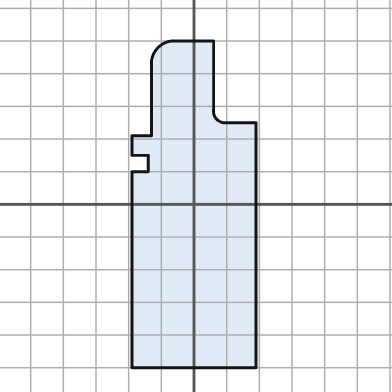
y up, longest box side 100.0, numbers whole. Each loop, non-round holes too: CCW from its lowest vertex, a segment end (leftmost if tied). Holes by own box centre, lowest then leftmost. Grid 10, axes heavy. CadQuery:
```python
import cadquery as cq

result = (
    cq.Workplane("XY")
    .moveTo(-19.0, -50.0)
    .lineTo(19.0, -50.0)
    .lineTo(19.0, 25.0)
    .lineTo(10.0, 25.0)
    .threePointArc((7.0, 26.0), (6.0, 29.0))
    .lineTo(6.0, 50.0)
    .lineTo(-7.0, 50.0)
    .threePointArc((-11.0, 48.0), (-13.0, 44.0))
    .lineTo(-13.0, 21.0)
    .lineTo(-19.0, 21.0)
    .lineTo(-19.0, 15.0)
    .lineTo(-14.0, 15.0)
    .lineTo(-14.0, 10.0)
    .lineTo(-19.0, 10.0)
    .close()
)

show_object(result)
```